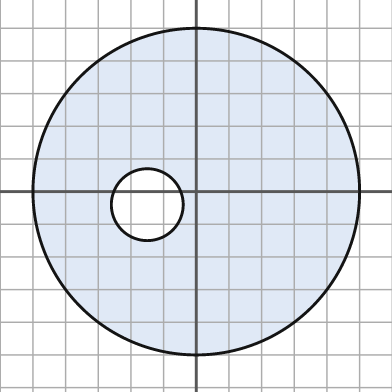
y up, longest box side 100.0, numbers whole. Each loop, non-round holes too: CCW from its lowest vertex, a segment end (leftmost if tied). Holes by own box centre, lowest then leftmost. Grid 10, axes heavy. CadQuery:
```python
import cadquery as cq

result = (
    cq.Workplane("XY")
    .moveTo(0.0, 0.0)
    .circle(50.0)
    .moveTo(-15.0, -4.0)
    .circle(11.0)
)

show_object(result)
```